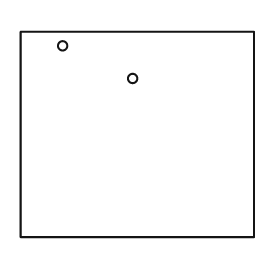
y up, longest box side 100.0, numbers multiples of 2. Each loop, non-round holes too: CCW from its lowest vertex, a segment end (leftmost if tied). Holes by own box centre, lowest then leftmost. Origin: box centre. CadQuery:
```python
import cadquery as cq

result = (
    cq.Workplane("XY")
    .moveTo(-50.0, -44.0)
    .lineTo(50.0, -44.0)
    .lineTo(50.0, 44.0)
    .lineTo(-50.0, 44.0)
    .close()
    .moveTo(-2.0, 24.0)
    .circle(2.0)
    .moveTo(-32.0, 38.0)
    .circle(2.0)
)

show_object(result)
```